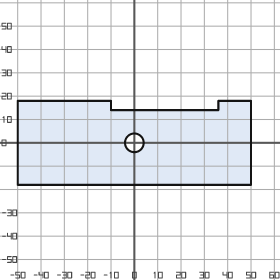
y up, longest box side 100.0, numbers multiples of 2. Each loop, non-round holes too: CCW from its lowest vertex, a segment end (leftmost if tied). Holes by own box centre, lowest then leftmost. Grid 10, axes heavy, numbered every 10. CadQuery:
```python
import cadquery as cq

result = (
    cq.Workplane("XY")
    .moveTo(-50.0, -18.0)
    .lineTo(50.0, -18.0)
    .lineTo(50.0, 18.0)
    .lineTo(36.0, 18.0)
    .lineTo(36.0, 14.0)
    .lineTo(-10.0, 14.0)
    .lineTo(-10.0, 18.0)
    .lineTo(-50.0, 18.0)
    .close()
    .moveTo(0.0, 0.0)
    .circle(4.0)
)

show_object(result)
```